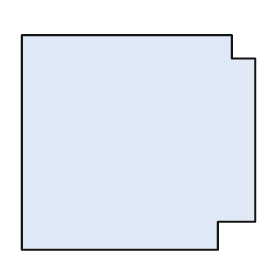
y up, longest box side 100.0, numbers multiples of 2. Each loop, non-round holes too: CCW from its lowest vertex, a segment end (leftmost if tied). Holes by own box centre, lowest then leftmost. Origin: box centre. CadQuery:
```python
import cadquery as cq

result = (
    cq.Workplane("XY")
    .moveTo(-50.0, -46.0)
    .lineTo(34.0, -46.0)
    .lineTo(34.0, -34.0)
    .lineTo(50.0, -34.0)
    .lineTo(50.0, 36.0)
    .lineTo(40.0, 36.0)
    .lineTo(40.0, 46.0)
    .lineTo(-50.0, 46.0)
    .close()
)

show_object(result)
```